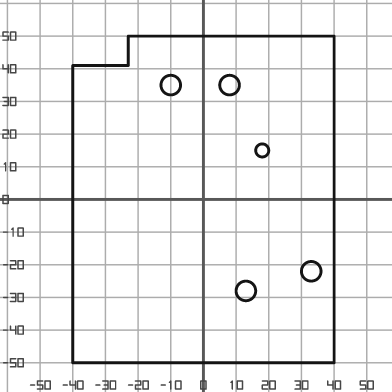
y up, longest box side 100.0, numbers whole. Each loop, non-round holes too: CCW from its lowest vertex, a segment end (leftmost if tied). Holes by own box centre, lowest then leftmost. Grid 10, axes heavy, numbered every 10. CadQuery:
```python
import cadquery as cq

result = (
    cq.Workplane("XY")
    .moveTo(-40.0, -50.0)
    .lineTo(40.0, -50.0)
    .lineTo(40.0, 50.0)
    .lineTo(-23.0, 50.0)
    .lineTo(-23.0, 41.0)
    .lineTo(-40.0, 41.0)
    .close()
    .moveTo(13.0, -28.0)
    .circle(3.0)
    .moveTo(33.0, -22.0)
    .circle(3.0)
    .moveTo(18.0, 15.0)
    .circle(2.0)
    .moveTo(-10.0, 35.0)
    .circle(3.0)
    .moveTo(8.0, 35.0)
    .circle(3.0)
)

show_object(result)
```